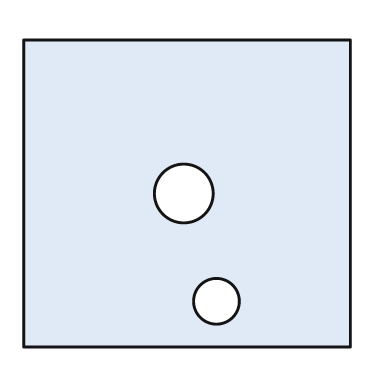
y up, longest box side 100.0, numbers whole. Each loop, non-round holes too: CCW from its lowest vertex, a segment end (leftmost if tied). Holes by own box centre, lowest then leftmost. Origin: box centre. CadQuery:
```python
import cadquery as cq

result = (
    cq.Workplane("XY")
    .moveTo(-50.0, -47.0)
    .lineTo(50.0, -47.0)
    .lineTo(50.0, 47.0)
    .lineTo(-50.0, 47.0)
    .close()
    .moveTo(9.0, -33.0)
    .circle(7.0)
    .moveTo(-1.0, 0.0)
    .circle(9.0)
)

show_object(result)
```